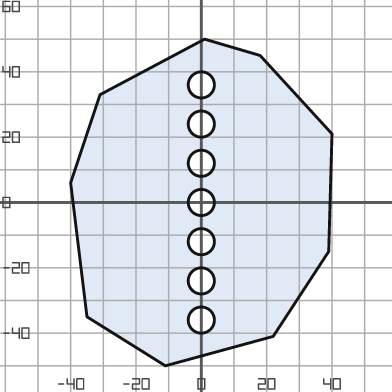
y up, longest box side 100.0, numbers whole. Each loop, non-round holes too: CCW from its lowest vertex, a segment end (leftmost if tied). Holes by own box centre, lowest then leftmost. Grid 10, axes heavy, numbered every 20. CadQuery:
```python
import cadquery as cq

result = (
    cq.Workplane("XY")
    .moveTo(-11.0, -50.0)
    .lineTo(22.0, -41.0)
    .lineTo(39.0, -15.0)
    .lineTo(40.0, 21.0)
    .lineTo(18.0, 45.0)
    .lineTo(1.0, 50.0)
    .lineTo(-31.0, 33.0)
    .lineTo(-40.0, 6.0)
    .lineTo(-35.0, -35.0)
    .close()
    .moveTo(0.0, -36.0)
    .circle(4.0)
    .moveTo(0.0, -24.0)
    .circle(4.0)
    .moveTo(0.0, -12.0)
    .circle(4.0)
    .moveTo(0.0, 0.0)
    .circle(4.0)
    .moveTo(0.0, 12.0)
    .circle(4.0)
    .moveTo(0.0, 24.0)
    .circle(4.0)
    .moveTo(0.0, 36.0)
    .circle(4.0)
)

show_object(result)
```